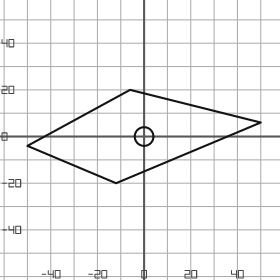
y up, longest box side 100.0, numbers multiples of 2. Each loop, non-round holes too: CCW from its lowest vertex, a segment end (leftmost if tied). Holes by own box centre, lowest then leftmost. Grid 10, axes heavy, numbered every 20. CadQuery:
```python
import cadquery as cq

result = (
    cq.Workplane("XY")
    .moveTo(-12.0, -20.0)
    .lineTo(50.0, 6.0)
    .lineTo(-6.0, 20.0)
    .lineTo(-50.0, -4.0)
    .close()
    .moveTo(0.0, 0.0)
    .circle(4.0)
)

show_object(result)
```